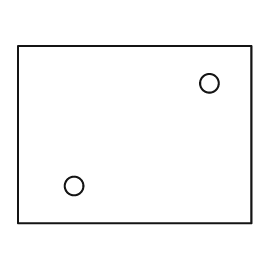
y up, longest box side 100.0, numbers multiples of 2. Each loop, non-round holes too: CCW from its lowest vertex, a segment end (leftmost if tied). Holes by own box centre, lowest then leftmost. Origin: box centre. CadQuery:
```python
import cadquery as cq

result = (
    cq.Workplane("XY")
    .moveTo(-50.0, -38.0)
    .lineTo(50.0, -38.0)
    .lineTo(50.0, 38.0)
    .lineTo(-50.0, 38.0)
    .close()
    .moveTo(-26.0, -22.0)
    .circle(4.0)
    .moveTo(32.0, 22.0)
    .circle(4.0)
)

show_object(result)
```